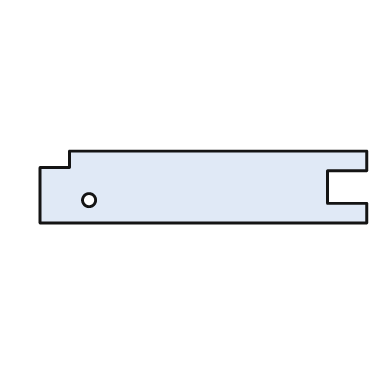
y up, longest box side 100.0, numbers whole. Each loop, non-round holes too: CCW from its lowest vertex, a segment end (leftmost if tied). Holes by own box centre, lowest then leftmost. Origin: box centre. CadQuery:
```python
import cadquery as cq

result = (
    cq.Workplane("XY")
    .moveTo(-50.0, -11.0)
    .lineTo(50.0, -11.0)
    .lineTo(50.0, -5.0)
    .lineTo(38.0, -5.0)
    .lineTo(38.0, 5.0)
    .lineTo(50.0, 5.0)
    .lineTo(50.0, 11.0)
    .lineTo(-41.0, 11.0)
    .lineTo(-41.0, 6.0)
    .lineTo(-50.0, 6.0)
    .close()
    .moveTo(-35.0, -4.0)
    .circle(2.0)
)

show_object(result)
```